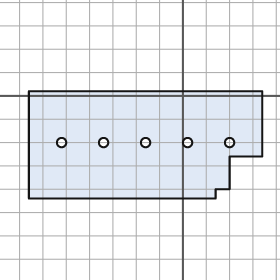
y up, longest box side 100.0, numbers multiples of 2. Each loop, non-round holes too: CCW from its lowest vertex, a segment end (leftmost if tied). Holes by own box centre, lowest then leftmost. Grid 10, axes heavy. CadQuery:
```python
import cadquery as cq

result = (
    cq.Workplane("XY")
    .moveTo(-66.0, -44.0)
    .lineTo(14.0, -44.0)
    .lineTo(14.0, -40.0)
    .lineTo(20.0, -40.0)
    .lineTo(20.0, -26.0)
    .lineTo(34.0, -26.0)
    .lineTo(34.0, 2.0)
    .lineTo(-66.0, 2.0)
    .close()
    .moveTo(-52.0, -20.0)
    .circle(2.0)
    .moveTo(-34.0, -20.0)
    .circle(2.0)
    .moveTo(-16.0, -20.0)
    .circle(2.0)
    .moveTo(2.0, -20.0)
    .circle(2.0)
    .moveTo(20.0, -20.0)
    .circle(2.0)
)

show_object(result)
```